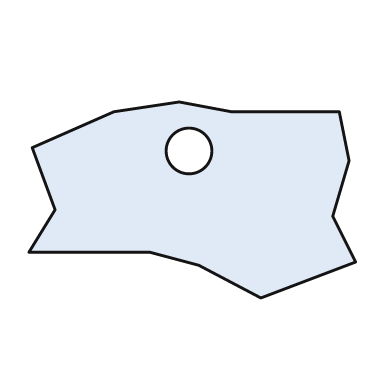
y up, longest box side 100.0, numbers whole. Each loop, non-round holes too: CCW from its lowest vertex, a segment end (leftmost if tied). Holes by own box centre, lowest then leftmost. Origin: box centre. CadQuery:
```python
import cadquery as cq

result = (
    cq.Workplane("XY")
    .moveTo(21.0, -30.0)
    .lineTo(50.0, -19.0)
    .lineTo(43.0, -5.0)
    .lineTo(48.0, 12.0)
    .lineTo(45.0, 27.0)
    .lineTo(12.0, 27.0)
    .lineTo(-4.0, 30.0)
    .lineTo(-24.0, 27.0)
    .lineTo(-49.0, 16.0)
    .lineTo(-42.0, -3.0)
    .lineTo(-50.0, -16.0)
    .lineTo(-13.0, -16.0)
    .lineTo(2.0, -20.0)
    .close()
    .moveTo(-1.0, 15.0)
    .circle(7.0)
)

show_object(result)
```